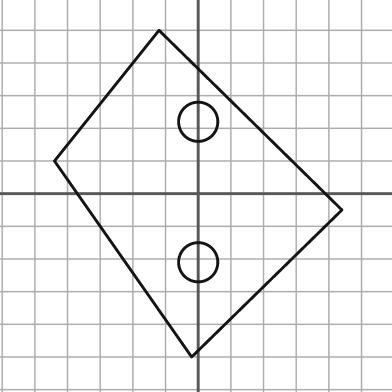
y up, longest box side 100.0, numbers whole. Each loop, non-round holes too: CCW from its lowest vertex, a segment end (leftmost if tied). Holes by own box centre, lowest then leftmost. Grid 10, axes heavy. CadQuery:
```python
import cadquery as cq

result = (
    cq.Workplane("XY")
    .moveTo(-2.0, -50.0)
    .lineTo(44.0, -5.0)
    .lineTo(-12.0, 50.0)
    .lineTo(-44.0, 10.0)
    .close()
    .moveTo(0.0, -21.0)
    .circle(6.0)
    .moveTo(0.0, 22.0)
    .circle(6.0)
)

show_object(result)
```